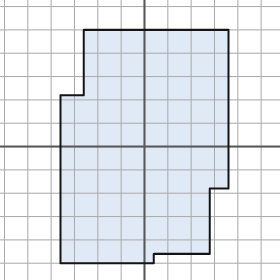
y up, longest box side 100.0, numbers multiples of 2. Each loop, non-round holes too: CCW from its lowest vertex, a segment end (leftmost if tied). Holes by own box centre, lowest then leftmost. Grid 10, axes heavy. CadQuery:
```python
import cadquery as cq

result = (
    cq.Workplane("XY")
    .moveTo(-36.0, -50.0)
    .lineTo(4.0, -50.0)
    .lineTo(4.0, -46.0)
    .lineTo(28.0, -46.0)
    .lineTo(28.0, -18.0)
    .lineTo(36.0, -18.0)
    .lineTo(36.0, 50.0)
    .lineTo(-26.0, 50.0)
    .lineTo(-26.0, 22.0)
    .lineTo(-36.0, 22.0)
    .close()
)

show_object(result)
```